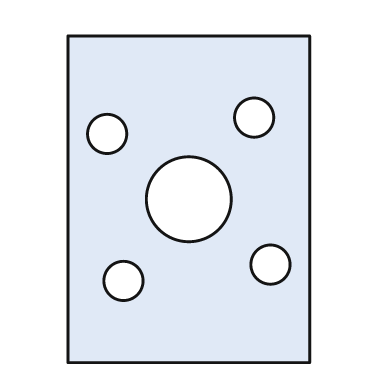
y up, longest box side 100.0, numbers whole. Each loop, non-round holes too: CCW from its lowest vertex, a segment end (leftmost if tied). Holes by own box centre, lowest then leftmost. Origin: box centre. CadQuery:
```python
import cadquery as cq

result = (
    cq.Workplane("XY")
    .moveTo(-37.0, -50.0)
    .lineTo(37.0, -50.0)
    .lineTo(37.0, 50.0)
    .lineTo(-37.0, 50.0)
    .close()
    .moveTo(-20.0, -25.0)
    .circle(6.0)
    .moveTo(25.0, -20.0)
    .circle(6.0)
    .moveTo(0.0, 0.0)
    .circle(13.0)
    .moveTo(-25.0, 20.0)
    .circle(6.0)
    .moveTo(20.0, 25.0)
    .circle(6.0)
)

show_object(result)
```